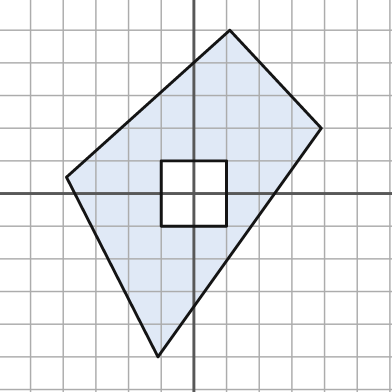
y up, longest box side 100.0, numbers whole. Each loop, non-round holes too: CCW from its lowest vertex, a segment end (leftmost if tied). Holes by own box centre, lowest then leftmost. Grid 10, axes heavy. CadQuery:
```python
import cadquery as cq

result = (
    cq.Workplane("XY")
    .moveTo(-11.0, -50.0)
    .lineTo(39.0, 20.0)
    .lineTo(11.0, 50.0)
    .lineTo(-39.0, 5.0)
    .close()
    .moveTo(-10.0, -10.0)
    .lineTo(10.0, -10.0)
    .lineTo(10.0, 10.0)
    .lineTo(-10.0, 10.0)
    .close()
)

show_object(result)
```